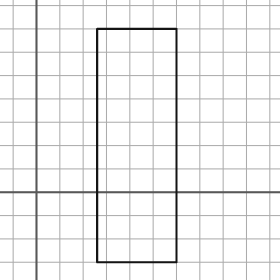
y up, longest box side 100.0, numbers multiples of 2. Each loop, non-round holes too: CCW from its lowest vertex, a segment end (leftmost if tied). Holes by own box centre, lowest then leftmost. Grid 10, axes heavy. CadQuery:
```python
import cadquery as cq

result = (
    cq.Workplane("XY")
    .moveTo(26.0, -30.0)
    .lineTo(60.0, -30.0)
    .lineTo(60.0, 70.0)
    .lineTo(26.0, 70.0)
    .close()
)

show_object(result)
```